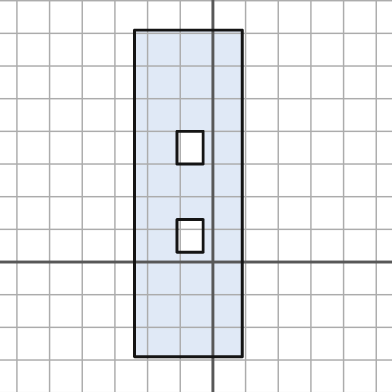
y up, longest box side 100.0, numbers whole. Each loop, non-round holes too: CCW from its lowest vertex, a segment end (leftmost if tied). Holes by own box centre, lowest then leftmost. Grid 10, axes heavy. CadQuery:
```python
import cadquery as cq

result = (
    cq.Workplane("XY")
    .moveTo(-24.0, -29.0)
    .lineTo(9.0, -29.0)
    .lineTo(9.0, 71.0)
    .lineTo(-24.0, 71.0)
    .close()
    .moveTo(-11.0, 3.0)
    .lineTo(-3.0, 3.0)
    .lineTo(-3.0, 13.0)
    .lineTo(-11.0, 13.0)
    .close()
    .moveTo(-11.0, 30.0)
    .lineTo(-3.0, 30.0)
    .lineTo(-3.0, 40.0)
    .lineTo(-11.0, 40.0)
    .close()
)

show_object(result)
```